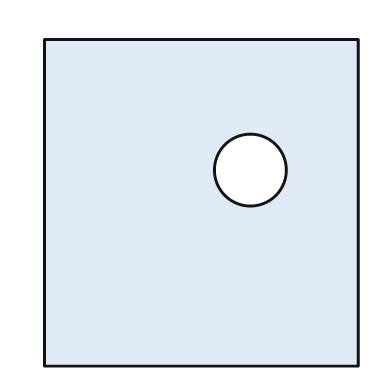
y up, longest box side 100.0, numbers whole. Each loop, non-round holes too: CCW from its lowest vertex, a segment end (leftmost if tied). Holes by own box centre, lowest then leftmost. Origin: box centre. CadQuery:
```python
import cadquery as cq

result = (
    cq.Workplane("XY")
    .moveTo(-48.0, -50.0)
    .lineTo(48.0, -50.0)
    .lineTo(48.0, 50.0)
    .lineTo(-48.0, 50.0)
    .close()
    .moveTo(15.0, 10.0)
    .circle(11.0)
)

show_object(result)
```